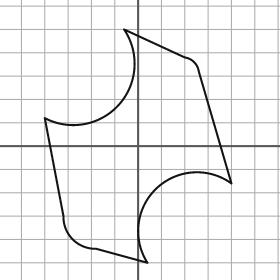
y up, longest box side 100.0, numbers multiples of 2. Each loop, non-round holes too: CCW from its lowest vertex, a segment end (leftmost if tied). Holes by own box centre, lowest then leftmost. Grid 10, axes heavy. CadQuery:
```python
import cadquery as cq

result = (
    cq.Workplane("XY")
    .moveTo(4.0, -50.0)
    .threePointArc((8.0, -18.0), (40.0, -16.0))
    .lineTo(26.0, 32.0)
    .threePointArc((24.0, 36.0), (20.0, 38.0))
    .lineTo(-6.0, 50.0)
    .threePointArc((-8.0, 18.0), (-40.0, 12.0))
    .lineTo(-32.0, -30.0)
    .threePointArc((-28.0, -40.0), (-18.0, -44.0))
    .close()
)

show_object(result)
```